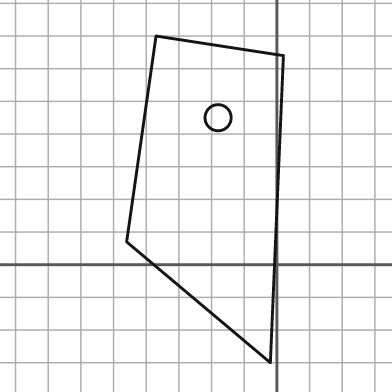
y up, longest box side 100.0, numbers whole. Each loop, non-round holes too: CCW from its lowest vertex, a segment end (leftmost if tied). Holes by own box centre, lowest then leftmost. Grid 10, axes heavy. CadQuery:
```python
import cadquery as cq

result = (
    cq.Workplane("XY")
    .moveTo(-2.0, -30.0)
    .lineTo(2.0, 64.0)
    .lineTo(-37.0, 70.0)
    .lineTo(-46.0, 7.0)
    .close()
    .moveTo(-18.0, 45.0)
    .circle(4.0)
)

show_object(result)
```